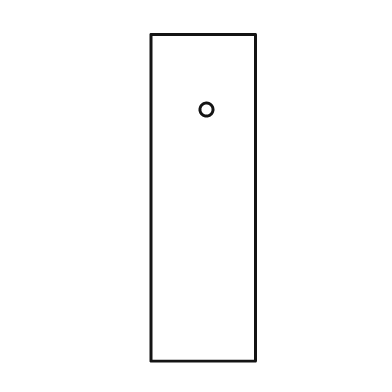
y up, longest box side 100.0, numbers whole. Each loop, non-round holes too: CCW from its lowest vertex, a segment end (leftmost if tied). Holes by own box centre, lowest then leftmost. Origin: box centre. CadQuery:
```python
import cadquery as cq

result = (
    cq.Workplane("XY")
    .moveTo(-16.0, -50.0)
    .lineTo(16.0, -50.0)
    .lineTo(16.0, 50.0)
    .lineTo(-16.0, 50.0)
    .close()
    .moveTo(1.0, 27.0)
    .circle(2.0)
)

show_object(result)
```